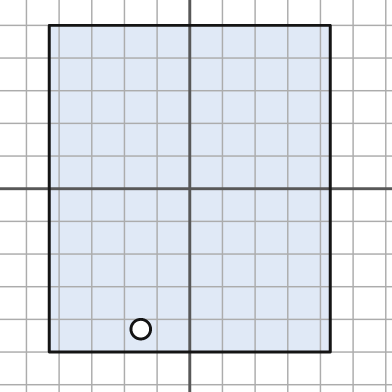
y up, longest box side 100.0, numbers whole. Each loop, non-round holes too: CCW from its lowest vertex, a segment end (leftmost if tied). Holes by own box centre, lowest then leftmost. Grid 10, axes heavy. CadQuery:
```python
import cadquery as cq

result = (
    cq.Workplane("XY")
    .moveTo(-43.0, -50.0)
    .lineTo(43.0, -50.0)
    .lineTo(43.0, 50.0)
    .lineTo(-43.0, 50.0)
    .close()
    .moveTo(-15.0, -43.0)
    .circle(3.0)
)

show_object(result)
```